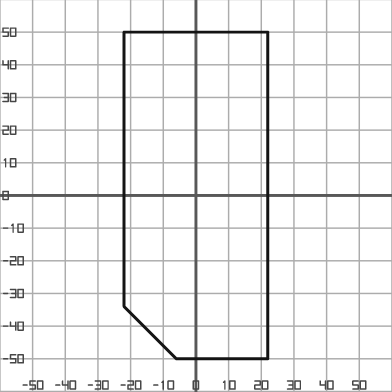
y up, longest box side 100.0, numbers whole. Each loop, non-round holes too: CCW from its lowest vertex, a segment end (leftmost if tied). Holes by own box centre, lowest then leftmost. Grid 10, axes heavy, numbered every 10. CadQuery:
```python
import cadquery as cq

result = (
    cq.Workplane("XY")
    .moveTo(-6.0, -50.0)
    .lineTo(22.0, -50.0)
    .lineTo(22.0, 50.0)
    .lineTo(-22.0, 50.0)
    .lineTo(-22.0, -34.0)
    .close()
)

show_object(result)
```